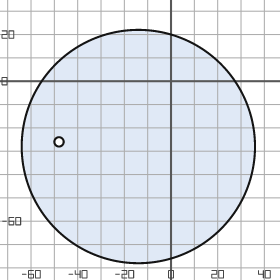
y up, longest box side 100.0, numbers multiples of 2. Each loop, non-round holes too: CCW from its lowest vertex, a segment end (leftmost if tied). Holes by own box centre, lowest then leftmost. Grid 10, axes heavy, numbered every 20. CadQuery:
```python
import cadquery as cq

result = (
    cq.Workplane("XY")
    .moveTo(-14.0, -28.0)
    .circle(50.0)
    .moveTo(-48.0, -26.0)
    .circle(2.0)
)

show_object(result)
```